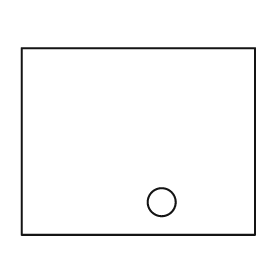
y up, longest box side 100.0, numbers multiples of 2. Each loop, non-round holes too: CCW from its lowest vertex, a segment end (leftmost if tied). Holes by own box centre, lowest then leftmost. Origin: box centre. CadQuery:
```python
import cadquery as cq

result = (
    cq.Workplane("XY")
    .moveTo(-50.0, -40.0)
    .lineTo(50.0, -40.0)
    .lineTo(50.0, 40.0)
    .lineTo(-50.0, 40.0)
    .close()
    .moveTo(10.0, -26.0)
    .circle(6.0)
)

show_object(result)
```